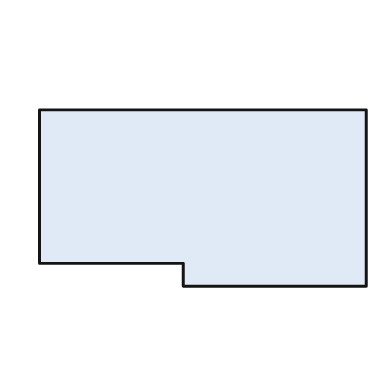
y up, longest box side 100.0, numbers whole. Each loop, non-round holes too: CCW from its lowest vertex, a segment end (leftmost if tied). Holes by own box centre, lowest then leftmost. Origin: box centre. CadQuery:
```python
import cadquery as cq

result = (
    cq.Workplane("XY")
    .moveTo(-6.0, -27.0)
    .lineTo(50.0, -27.0)
    .lineTo(50.0, 27.0)
    .lineTo(-50.0, 27.0)
    .lineTo(-50.0, -20.0)
    .lineTo(-6.0, -20.0)
    .close()
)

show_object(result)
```